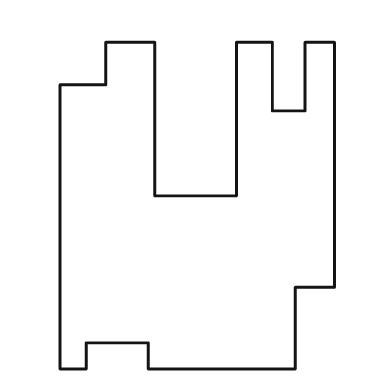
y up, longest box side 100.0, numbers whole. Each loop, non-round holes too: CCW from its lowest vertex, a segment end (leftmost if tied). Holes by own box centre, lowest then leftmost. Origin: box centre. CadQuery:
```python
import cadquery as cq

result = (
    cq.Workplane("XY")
    .moveTo(-42.0, -50.0)
    .lineTo(-34.0, -50.0)
    .lineTo(-34.0, -42.0)
    .lineTo(-15.0, -42.0)
    .lineTo(-15.0, -50.0)
    .lineTo(30.0, -50.0)
    .lineTo(30.0, -25.0)
    .lineTo(42.0, -25.0)
    .lineTo(42.0, 50.0)
    .lineTo(33.0, 50.0)
    .lineTo(33.0, 29.0)
    .lineTo(23.0, 29.0)
    .lineTo(23.0, 50.0)
    .lineTo(12.0, 50.0)
    .lineTo(12.0, 3.0)
    .lineTo(-13.0, 3.0)
    .lineTo(-13.0, 50.0)
    .lineTo(-28.0, 50.0)
    .lineTo(-28.0, 37.0)
    .lineTo(-42.0, 37.0)
    .close()
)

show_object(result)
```